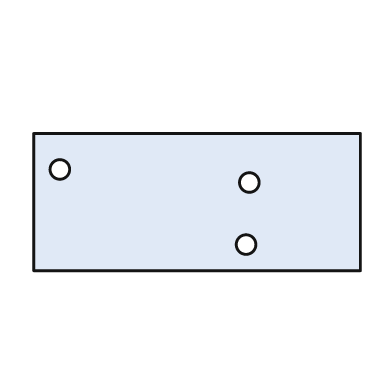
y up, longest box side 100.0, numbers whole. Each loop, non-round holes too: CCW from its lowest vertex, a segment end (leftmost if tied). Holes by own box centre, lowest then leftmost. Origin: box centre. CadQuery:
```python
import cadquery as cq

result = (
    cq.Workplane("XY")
    .moveTo(-50.0, -21.0)
    .lineTo(50.0, -21.0)
    .lineTo(50.0, 21.0)
    .lineTo(-50.0, 21.0)
    .close()
    .moveTo(15.0, -13.0)
    .circle(3.0)
    .moveTo(16.0, 6.0)
    .circle(3.0)
    .moveTo(-42.0, 10.0)
    .circle(3.0)
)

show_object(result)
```